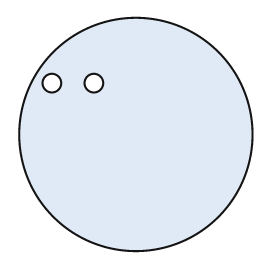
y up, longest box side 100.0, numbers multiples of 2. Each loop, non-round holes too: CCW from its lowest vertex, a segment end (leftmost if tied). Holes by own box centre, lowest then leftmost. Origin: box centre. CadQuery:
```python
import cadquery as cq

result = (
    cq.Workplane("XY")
    .moveTo(0.0, 0.0)
    .circle(50.0)
    .moveTo(-36.0, 22.0)
    .circle(4.0)
    .moveTo(-18.0, 22.0)
    .circle(4.0)
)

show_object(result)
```